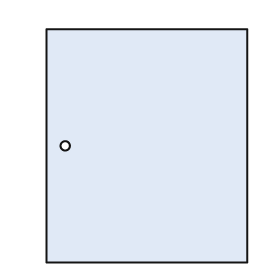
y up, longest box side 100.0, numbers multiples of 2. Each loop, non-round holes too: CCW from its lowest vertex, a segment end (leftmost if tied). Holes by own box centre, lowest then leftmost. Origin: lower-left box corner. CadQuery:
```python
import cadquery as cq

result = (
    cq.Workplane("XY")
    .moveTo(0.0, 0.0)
    .lineTo(86.0, 0.0)
    .lineTo(86.0, 100.0)
    .lineTo(0.0, 100.0)
    .close()
    .moveTo(8.0, 50.0)
    .circle(2.0)
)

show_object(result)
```